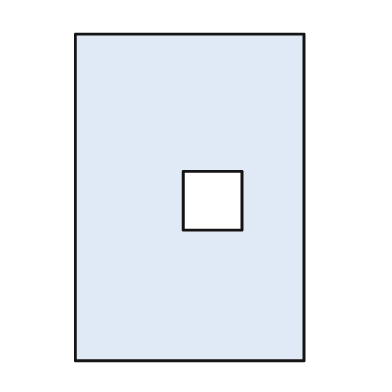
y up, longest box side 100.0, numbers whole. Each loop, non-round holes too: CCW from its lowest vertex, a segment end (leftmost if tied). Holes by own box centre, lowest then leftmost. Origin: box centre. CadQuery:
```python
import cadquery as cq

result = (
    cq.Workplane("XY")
    .moveTo(-35.0, -50.0)
    .lineTo(35.0, -50.0)
    .lineTo(35.0, 50.0)
    .lineTo(-35.0, 50.0)
    .close()
    .moveTo(-2.0, -10.0)
    .lineTo(16.0, -10.0)
    .lineTo(16.0, 8.0)
    .lineTo(-2.0, 8.0)
    .close()
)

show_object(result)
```